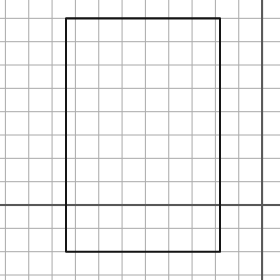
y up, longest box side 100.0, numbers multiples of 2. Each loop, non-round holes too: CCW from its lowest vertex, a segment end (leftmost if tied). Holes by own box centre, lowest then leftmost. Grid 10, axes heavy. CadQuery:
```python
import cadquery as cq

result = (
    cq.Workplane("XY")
    .moveTo(-84.0, -20.0)
    .lineTo(-18.0, -20.0)
    .lineTo(-18.0, 80.0)
    .lineTo(-84.0, 80.0)
    .close()
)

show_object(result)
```